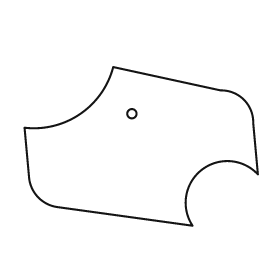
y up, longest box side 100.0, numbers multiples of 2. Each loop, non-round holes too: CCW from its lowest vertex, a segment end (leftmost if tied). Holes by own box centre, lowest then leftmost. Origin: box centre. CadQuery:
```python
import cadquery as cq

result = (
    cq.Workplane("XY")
    .moveTo(22.0, -34.0)
    .threePointArc((26.0, -10.0), (50.0, -12.0))
    .lineTo(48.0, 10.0)
    .threePointArc((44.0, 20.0), (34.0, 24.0))
    .lineTo(-12.0, 34.0)
    .threePointArc((-26.0, 14.0), (-50.0, 8.0))
    .lineTo(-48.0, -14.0)
    .threePointArc((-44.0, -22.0), (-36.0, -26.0))
    .close()
    .moveTo(-4.0, 14.0)
    .circle(2.0)
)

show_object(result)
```